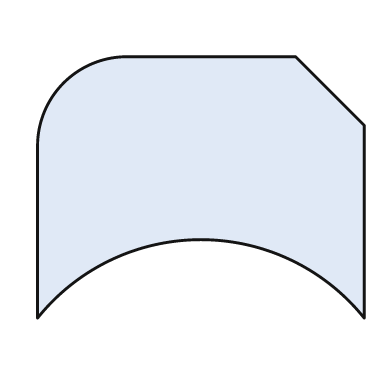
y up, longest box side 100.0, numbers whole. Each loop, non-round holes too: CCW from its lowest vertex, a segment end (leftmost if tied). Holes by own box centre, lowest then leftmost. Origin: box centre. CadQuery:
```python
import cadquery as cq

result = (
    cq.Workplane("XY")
    .moveTo(-50.0, -40.0)
    .threePointArc((0.0, -16.0), (50.0, -40.0))
    .lineTo(50.0, 19.0)
    .lineTo(29.0, 40.0)
    .lineTo(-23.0, 40.0)
    .threePointArc((-42.0, 32.0), (-50.0, 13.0))
    .close()
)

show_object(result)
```